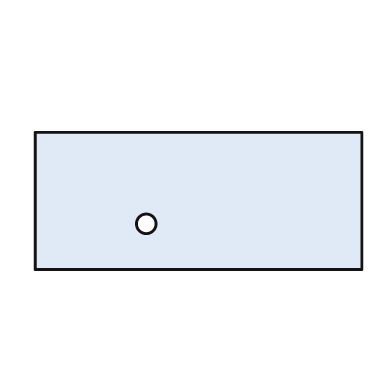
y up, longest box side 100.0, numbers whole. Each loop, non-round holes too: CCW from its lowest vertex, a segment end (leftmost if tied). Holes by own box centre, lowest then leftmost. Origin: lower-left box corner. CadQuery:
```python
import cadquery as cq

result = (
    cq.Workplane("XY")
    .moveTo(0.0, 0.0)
    .lineTo(100.0, 0.0)
    .lineTo(100.0, 42.0)
    .lineTo(0.0, 42.0)
    .close()
    .moveTo(34.0, 14.0)
    .circle(3.0)
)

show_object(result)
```